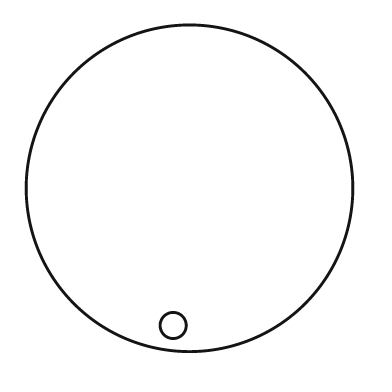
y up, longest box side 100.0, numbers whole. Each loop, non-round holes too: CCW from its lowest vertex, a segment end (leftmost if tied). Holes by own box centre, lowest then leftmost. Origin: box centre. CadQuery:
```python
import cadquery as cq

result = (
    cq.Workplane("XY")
    .moveTo(0.0, 0.0)
    .circle(50.0)
    .moveTo(-5.0, -42.0)
    .circle(4.0)
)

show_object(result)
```